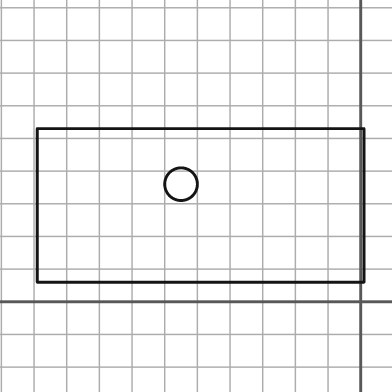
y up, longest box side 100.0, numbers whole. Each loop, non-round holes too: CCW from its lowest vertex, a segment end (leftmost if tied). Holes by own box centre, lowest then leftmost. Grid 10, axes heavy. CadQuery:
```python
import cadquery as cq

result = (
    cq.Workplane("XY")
    .moveTo(-99.0, 6.0)
    .lineTo(1.0, 6.0)
    .lineTo(1.0, 53.0)
    .lineTo(-99.0, 53.0)
    .close()
    .moveTo(-55.0, 36.0)
    .circle(5.0)
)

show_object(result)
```